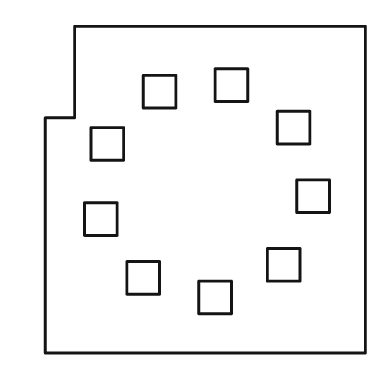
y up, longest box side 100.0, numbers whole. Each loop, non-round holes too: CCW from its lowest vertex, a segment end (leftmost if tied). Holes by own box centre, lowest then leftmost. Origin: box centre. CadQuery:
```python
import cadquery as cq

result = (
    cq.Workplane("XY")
    .moveTo(-49.0, -50.0)
    .lineTo(49.0, -50.0)
    .lineTo(49.0, 50.0)
    .lineTo(-40.0, 50.0)
    .lineTo(-40.0, 22.0)
    .lineTo(-49.0, 22.0)
    .close()
    .moveTo(-2.0, -38.0)
    .lineTo(8.0, -38.0)
    .lineTo(8.0, -28.0)
    .lineTo(-2.0, -28.0)
    .close()
    .moveTo(-24.0, -32.0)
    .lineTo(-14.0, -32.0)
    .lineTo(-14.0, -22.0)
    .lineTo(-24.0, -22.0)
    .close()
    .moveTo(19.0, -28.0)
    .lineTo(29.0, -28.0)
    .lineTo(29.0, -18.0)
    .lineTo(19.0, -18.0)
    .close()
    .moveTo(-37.0, -14.0)
    .lineTo(-27.0, -14.0)
    .lineTo(-27.0, -4.0)
    .lineTo(-37.0, -4.0)
    .close()
    .moveTo(28.0, -7.0)
    .lineTo(38.0, -7.0)
    .lineTo(38.0, 3.0)
    .lineTo(28.0, 3.0)
    .close()
    .moveTo(-35.0, 9.0)
    .lineTo(-25.0, 9.0)
    .lineTo(-25.0, 19.0)
    .lineTo(-35.0, 19.0)
    .close()
    .moveTo(22.0, 14.0)
    .lineTo(32.0, 14.0)
    .lineTo(32.0, 24.0)
    .lineTo(22.0, 24.0)
    .close()
    .moveTo(-19.0, 25.0)
    .lineTo(-9.0, 25.0)
    .lineTo(-9.0, 35.0)
    .lineTo(-19.0, 35.0)
    .close()
    .moveTo(3.0, 27.0)
    .lineTo(13.0, 27.0)
    .lineTo(13.0, 37.0)
    .lineTo(3.0, 37.0)
    .close()
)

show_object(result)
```